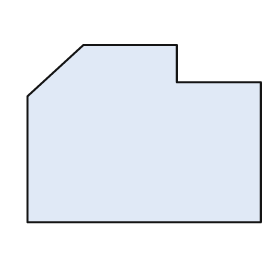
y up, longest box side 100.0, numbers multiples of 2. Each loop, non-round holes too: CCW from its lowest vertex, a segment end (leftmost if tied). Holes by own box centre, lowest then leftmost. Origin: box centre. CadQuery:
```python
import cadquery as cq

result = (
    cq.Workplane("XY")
    .moveTo(-50.0, -38.0)
    .lineTo(50.0, -38.0)
    .lineTo(50.0, 22.0)
    .lineTo(14.0, 22.0)
    .lineTo(14.0, 38.0)
    .lineTo(-26.0, 38.0)
    .lineTo(-50.0, 16.0)
    .close()
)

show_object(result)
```